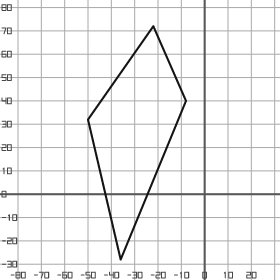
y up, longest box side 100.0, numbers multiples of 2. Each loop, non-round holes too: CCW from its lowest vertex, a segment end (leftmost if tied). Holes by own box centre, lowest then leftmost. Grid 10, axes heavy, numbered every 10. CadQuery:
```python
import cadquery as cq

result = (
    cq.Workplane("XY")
    .moveTo(-36.0, -28.0)
    .lineTo(-8.0, 40.0)
    .lineTo(-22.0, 72.0)
    .lineTo(-50.0, 32.0)
    .close()
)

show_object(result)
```